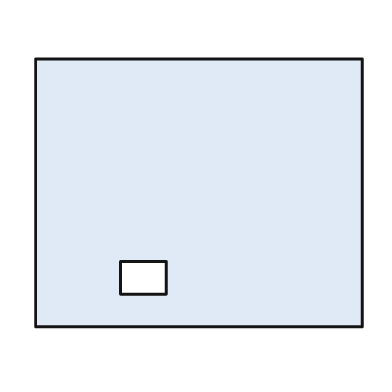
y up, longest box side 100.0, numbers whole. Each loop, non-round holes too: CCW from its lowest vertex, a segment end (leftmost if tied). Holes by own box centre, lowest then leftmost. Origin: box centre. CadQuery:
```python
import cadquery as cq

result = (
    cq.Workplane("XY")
    .moveTo(-50.0, -41.0)
    .lineTo(50.0, -41.0)
    .lineTo(50.0, 41.0)
    .lineTo(-50.0, 41.0)
    .close()
    .moveTo(-24.0, -31.0)
    .lineTo(-10.0, -31.0)
    .lineTo(-10.0, -21.0)
    .lineTo(-24.0, -21.0)
    .close()
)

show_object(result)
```